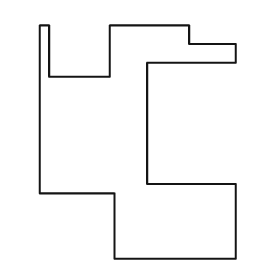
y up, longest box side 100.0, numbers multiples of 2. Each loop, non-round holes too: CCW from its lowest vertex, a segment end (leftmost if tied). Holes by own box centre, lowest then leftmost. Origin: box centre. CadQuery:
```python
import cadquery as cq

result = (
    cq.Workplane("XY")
    .moveTo(-10.0, -50.0)
    .lineTo(42.0, -50.0)
    .lineTo(42.0, -18.0)
    .lineTo(4.0, -18.0)
    .lineTo(4.0, 34.0)
    .lineTo(42.0, 34.0)
    .lineTo(42.0, 42.0)
    .lineTo(22.0, 42.0)
    .lineTo(22.0, 50.0)
    .lineTo(-12.0, 50.0)
    .lineTo(-12.0, 28.0)
    .lineTo(-38.0, 28.0)
    .lineTo(-38.0, 50.0)
    .lineTo(-42.0, 50.0)
    .lineTo(-42.0, -22.0)
    .lineTo(-10.0, -22.0)
    .close()
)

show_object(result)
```